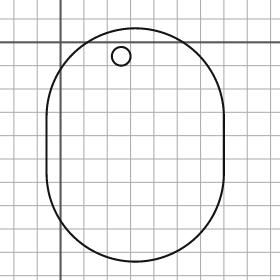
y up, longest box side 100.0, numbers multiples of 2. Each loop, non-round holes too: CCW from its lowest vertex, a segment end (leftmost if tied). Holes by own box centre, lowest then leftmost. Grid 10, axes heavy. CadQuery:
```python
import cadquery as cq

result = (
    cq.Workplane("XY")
    .moveTo(-6.0, -56.0)
    .threePointArc((32.0, -94.0), (70.0, -56.0))
    .lineTo(70.0, -32.0)
    .threePointArc((32.0, 6.0), (-6.0, -32.0))
    .close()
    .moveTo(26.0, -6.0)
    .circle(4.0)
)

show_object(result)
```